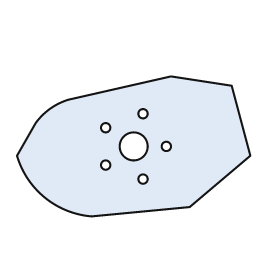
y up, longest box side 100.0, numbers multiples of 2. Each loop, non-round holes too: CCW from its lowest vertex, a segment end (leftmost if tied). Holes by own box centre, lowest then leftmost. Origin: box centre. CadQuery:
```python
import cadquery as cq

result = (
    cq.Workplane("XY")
    .moveTo(-18.0, -30.0)
    .lineTo(24.0, -26.0)
    .lineTo(50.0, -4.0)
    .lineTo(42.0, 26.0)
    .lineTo(16.0, 30.0)
    .lineTo(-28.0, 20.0)
    .threePointArc((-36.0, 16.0), (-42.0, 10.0))
    .lineTo(-50.0, -4.0)
    .threePointArc((-38.0, -22.0), (-18.0, -30.0))
    .close()
    .moveTo(4.0, -14.0)
    .circle(2.0)
    .moveTo(-12.0, -8.0)
    .circle(2.0)
    .moveTo(0.0, 0.0)
    .circle(6.0)
    .moveTo(14.0, 0.0)
    .circle(2.0)
    .moveTo(-12.0, 8.0)
    .circle(2.0)
    .moveTo(4.0, 14.0)
    .circle(2.0)
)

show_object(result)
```